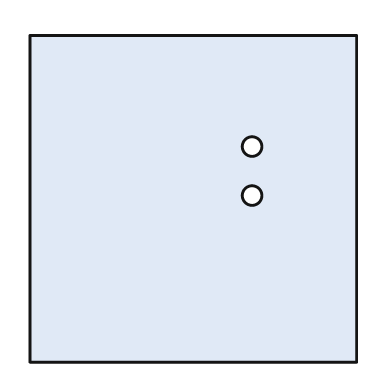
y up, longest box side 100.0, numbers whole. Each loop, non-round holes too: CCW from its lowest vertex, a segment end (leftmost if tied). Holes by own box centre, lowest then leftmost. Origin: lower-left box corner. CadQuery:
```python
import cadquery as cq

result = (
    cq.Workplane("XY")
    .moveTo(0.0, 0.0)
    .lineTo(100.0, 0.0)
    .lineTo(100.0, 100.0)
    .lineTo(0.0, 100.0)
    .close()
    .moveTo(68.0, 51.0)
    .circle(3.0)
    .moveTo(68.0, 66.0)
    .circle(3.0)
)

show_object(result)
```